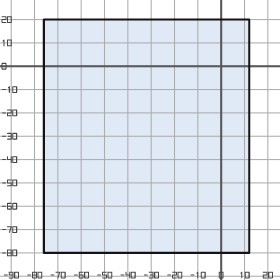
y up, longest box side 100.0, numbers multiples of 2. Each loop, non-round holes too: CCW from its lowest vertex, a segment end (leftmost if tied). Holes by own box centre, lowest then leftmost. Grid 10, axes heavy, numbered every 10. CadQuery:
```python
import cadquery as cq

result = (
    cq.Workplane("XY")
    .moveTo(-76.0, -80.0)
    .lineTo(12.0, -80.0)
    .lineTo(12.0, 20.0)
    .lineTo(-76.0, 20.0)
    .close()
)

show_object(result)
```